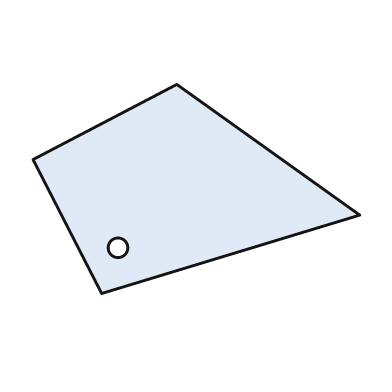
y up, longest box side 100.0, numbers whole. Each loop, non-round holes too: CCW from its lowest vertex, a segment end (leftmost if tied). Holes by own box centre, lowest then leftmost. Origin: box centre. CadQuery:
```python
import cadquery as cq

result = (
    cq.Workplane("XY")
    .moveTo(-29.0, -32.0)
    .lineTo(50.0, -8.0)
    .lineTo(-6.0, 32.0)
    .lineTo(-50.0, 9.0)
    .close()
    .moveTo(-24.0, -18.0)
    .circle(3.0)
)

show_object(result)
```